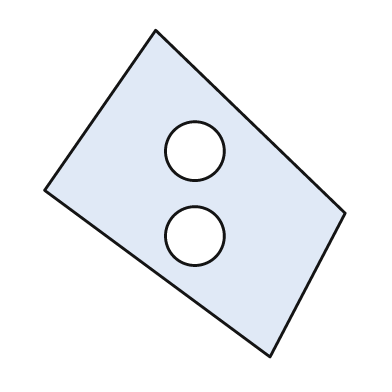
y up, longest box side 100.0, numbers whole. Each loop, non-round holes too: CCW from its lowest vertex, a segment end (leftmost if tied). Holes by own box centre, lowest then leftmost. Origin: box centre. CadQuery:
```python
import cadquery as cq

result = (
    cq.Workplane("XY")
    .moveTo(23.0, -50.0)
    .lineTo(46.0, -6.0)
    .lineTo(-12.0, 50.0)
    .lineTo(-46.0, 1.0)
    .close()
    .moveTo(0.0, -13.0)
    .circle(9.0)
    .moveTo(0.0, 13.0)
    .circle(9.0)
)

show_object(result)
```